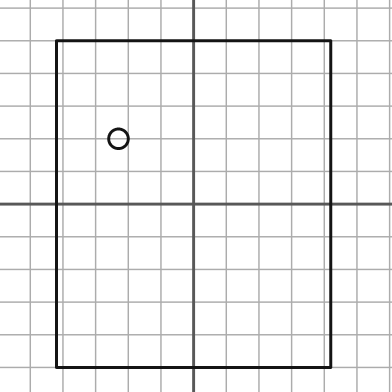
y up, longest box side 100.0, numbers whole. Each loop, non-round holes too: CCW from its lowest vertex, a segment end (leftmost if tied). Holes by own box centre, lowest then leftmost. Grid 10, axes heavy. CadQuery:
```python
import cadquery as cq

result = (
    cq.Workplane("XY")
    .moveTo(-42.0, -50.0)
    .lineTo(42.0, -50.0)
    .lineTo(42.0, 50.0)
    .lineTo(-42.0, 50.0)
    .close()
    .moveTo(-23.0, 20.0)
    .circle(3.0)
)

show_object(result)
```